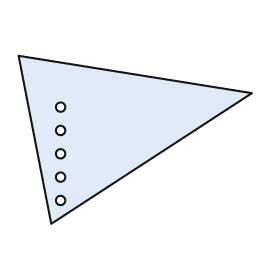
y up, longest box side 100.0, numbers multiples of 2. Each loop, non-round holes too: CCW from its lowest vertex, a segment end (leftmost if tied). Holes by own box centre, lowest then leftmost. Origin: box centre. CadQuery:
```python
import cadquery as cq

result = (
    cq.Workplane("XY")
    .moveTo(-36.0, -36.0)
    .lineTo(50.0, 20.0)
    .lineTo(-50.0, 36.0)
    .close()
    .moveTo(-32.0, -26.0)
    .circle(2.0)
    .moveTo(-32.0, -16.0)
    .circle(2.0)
    .moveTo(-32.0, -6.0)
    .circle(2.0)
    .moveTo(-32.0, 4.0)
    .circle(2.0)
    .moveTo(-32.0, 14.0)
    .circle(2.0)
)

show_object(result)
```